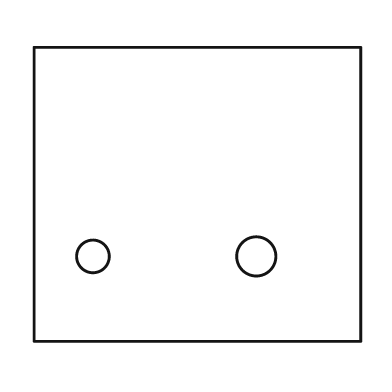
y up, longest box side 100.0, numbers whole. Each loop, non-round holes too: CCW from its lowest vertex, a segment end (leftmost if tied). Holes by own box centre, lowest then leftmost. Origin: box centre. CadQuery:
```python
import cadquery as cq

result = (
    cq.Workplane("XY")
    .moveTo(-50.0, -45.0)
    .lineTo(50.0, -45.0)
    .lineTo(50.0, 45.0)
    .lineTo(-50.0, 45.0)
    .close()
    .moveTo(-32.0, -19.0)
    .circle(5.0)
    .moveTo(18.0, -19.0)
    .circle(6.0)
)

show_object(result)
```